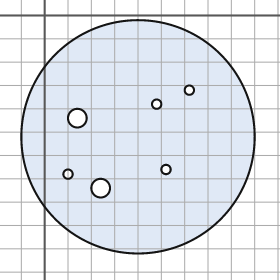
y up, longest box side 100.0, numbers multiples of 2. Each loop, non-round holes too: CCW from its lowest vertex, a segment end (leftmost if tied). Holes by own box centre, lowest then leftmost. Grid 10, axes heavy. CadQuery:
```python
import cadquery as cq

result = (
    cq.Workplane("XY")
    .moveTo(40.0, -52.0)
    .circle(50.0)
    .moveTo(24.0, -74.0)
    .circle(4.0)
    .moveTo(10.0, -68.0)
    .circle(2.0)
    .moveTo(52.0, -66.0)
    .circle(2.0)
    .moveTo(14.0, -44.0)
    .circle(4.0)
    .moveTo(48.0, -38.0)
    .circle(2.0)
    .moveTo(62.0, -32.0)
    .circle(2.0)
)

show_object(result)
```